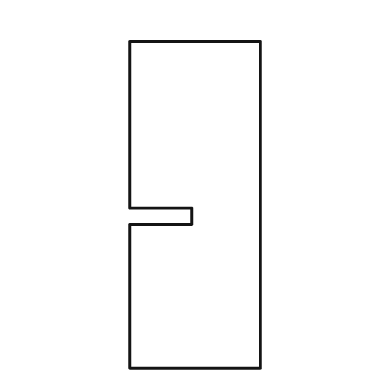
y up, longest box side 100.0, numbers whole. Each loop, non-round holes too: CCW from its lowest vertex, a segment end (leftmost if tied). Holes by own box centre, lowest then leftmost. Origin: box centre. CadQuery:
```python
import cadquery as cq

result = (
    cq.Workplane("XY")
    .moveTo(-20.0, -50.0)
    .lineTo(20.0, -50.0)
    .lineTo(20.0, 50.0)
    .lineTo(-20.0, 50.0)
    .lineTo(-20.0, -1.0)
    .lineTo(-1.0, -1.0)
    .lineTo(-1.0, -6.0)
    .lineTo(-20.0, -6.0)
    .close()
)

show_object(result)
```